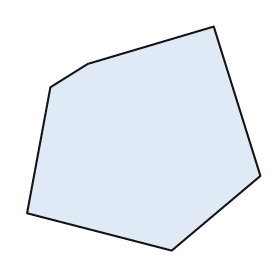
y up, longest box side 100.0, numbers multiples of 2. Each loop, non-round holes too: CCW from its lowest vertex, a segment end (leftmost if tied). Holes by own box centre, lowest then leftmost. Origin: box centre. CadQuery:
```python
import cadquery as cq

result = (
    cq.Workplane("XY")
    .moveTo(12.0, -48.0)
    .lineTo(50.0, -16.0)
    .lineTo(30.0, 48.0)
    .lineTo(-24.0, 32.0)
    .lineTo(-40.0, 22.0)
    .lineTo(-50.0, -32.0)
    .close()
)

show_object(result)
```